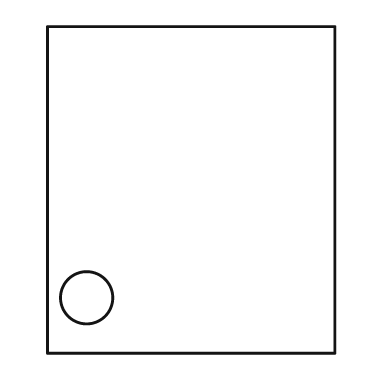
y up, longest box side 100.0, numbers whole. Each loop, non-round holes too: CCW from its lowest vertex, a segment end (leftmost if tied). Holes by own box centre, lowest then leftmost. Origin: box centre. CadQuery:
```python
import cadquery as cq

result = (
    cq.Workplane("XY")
    .moveTo(-44.0, -50.0)
    .lineTo(44.0, -50.0)
    .lineTo(44.0, 50.0)
    .lineTo(-44.0, 50.0)
    .close()
    .moveTo(-32.0, -33.0)
    .circle(8.0)
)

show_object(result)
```